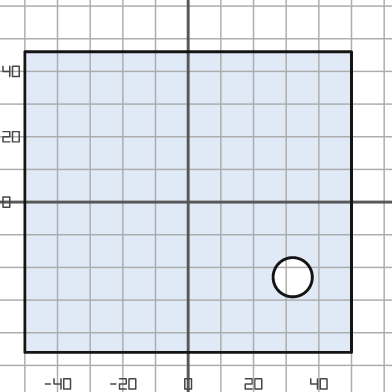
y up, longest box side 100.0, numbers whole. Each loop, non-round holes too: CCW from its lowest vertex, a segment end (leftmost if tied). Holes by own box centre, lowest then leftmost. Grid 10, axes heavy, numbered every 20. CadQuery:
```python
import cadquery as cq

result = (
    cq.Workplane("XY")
    .moveTo(-50.0, -46.0)
    .lineTo(50.0, -46.0)
    .lineTo(50.0, 46.0)
    .lineTo(-50.0, 46.0)
    .close()
    .moveTo(32.0, -23.0)
    .circle(6.0)
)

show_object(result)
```